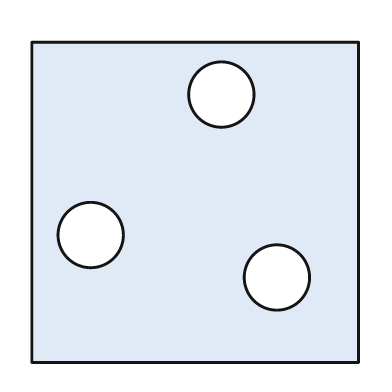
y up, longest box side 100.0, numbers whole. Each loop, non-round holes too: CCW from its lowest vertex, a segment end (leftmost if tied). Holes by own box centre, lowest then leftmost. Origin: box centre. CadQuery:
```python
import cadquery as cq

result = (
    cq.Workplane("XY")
    .moveTo(-50.0, -49.0)
    .lineTo(50.0, -49.0)
    .lineTo(50.0, 49.0)
    .lineTo(-50.0, 49.0)
    .close()
    .moveTo(25.0, -23.0)
    .circle(10.0)
    .moveTo(-32.0, -10.0)
    .circle(10.0)
    .moveTo(8.0, 33.0)
    .circle(10.0)
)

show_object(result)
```